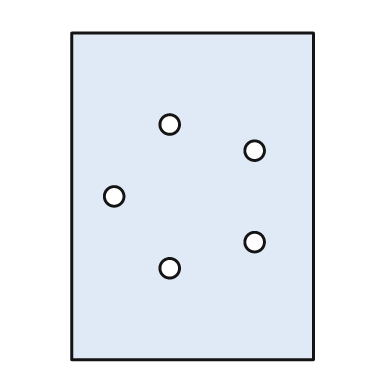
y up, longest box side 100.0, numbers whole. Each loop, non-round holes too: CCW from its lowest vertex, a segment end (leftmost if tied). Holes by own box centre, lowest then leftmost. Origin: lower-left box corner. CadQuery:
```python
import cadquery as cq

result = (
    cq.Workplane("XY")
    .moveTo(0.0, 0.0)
    .lineTo(74.0, 0.0)
    .lineTo(74.0, 100.0)
    .lineTo(0.0, 100.0)
    .close()
    .moveTo(30.0, 28.0)
    .circle(3.0)
    .moveTo(56.0, 36.0)
    .circle(3.0)
    .moveTo(13.0, 50.0)
    .circle(3.0)
    .moveTo(56.0, 64.0)
    .circle(3.0)
    .moveTo(30.0, 72.0)
    .circle(3.0)
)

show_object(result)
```